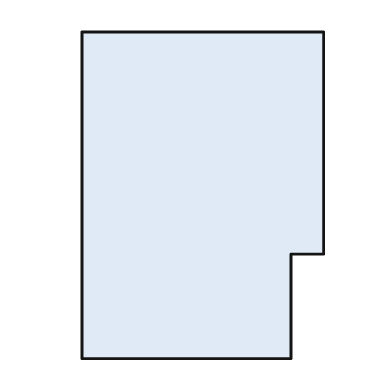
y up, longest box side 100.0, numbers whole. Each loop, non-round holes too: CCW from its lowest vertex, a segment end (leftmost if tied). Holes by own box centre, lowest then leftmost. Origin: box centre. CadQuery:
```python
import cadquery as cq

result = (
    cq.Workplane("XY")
    .moveTo(-37.0, -50.0)
    .lineTo(27.0, -50.0)
    .lineTo(27.0, -18.0)
    .lineTo(37.0, -18.0)
    .lineTo(37.0, 50.0)
    .lineTo(-37.0, 50.0)
    .close()
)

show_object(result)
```